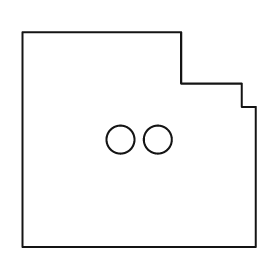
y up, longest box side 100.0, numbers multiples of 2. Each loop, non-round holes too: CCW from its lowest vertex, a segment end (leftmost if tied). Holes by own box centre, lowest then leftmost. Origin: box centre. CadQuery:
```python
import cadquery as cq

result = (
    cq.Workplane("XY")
    .moveTo(-50.0, -46.0)
    .lineTo(50.0, -46.0)
    .lineTo(50.0, 14.0)
    .lineTo(44.0, 14.0)
    .lineTo(44.0, 24.0)
    .lineTo(18.0, 24.0)
    .lineTo(18.0, 46.0)
    .lineTo(-50.0, 46.0)
    .close()
    .moveTo(-8.0, 0.0)
    .circle(6.0)
    .moveTo(8.0, 0.0)
    .circle(6.0)
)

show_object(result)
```